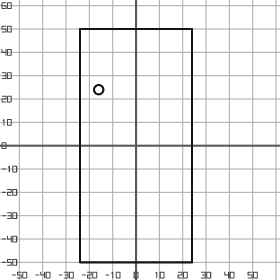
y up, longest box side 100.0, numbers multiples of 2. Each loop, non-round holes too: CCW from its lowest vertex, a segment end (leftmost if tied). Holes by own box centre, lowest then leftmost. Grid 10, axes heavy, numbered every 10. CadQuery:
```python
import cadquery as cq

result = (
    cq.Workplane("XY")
    .moveTo(-24.0, -50.0)
    .lineTo(24.0, -50.0)
    .lineTo(24.0, 50.0)
    .lineTo(-24.0, 50.0)
    .close()
    .moveTo(-16.0, 24.0)
    .circle(2.0)
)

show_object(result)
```